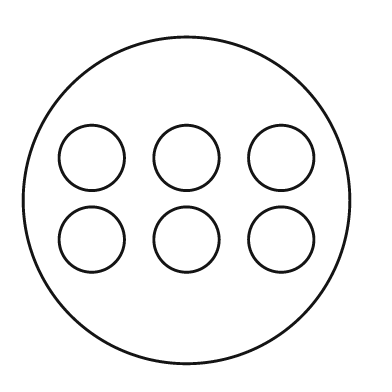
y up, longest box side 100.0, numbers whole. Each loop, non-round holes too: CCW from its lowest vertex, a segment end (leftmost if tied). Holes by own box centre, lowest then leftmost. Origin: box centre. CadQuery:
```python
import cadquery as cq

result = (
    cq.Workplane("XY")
    .moveTo(0.0, 0.0)
    .circle(50.0)
    .moveTo(-29.0, -12.0)
    .circle(10.0)
    .moveTo(0.0, -12.0)
    .circle(10.0)
    .moveTo(29.0, -12.0)
    .circle(10.0)
    .moveTo(-29.0, 13.0)
    .circle(10.0)
    .moveTo(0.0, 13.0)
    .circle(10.0)
    .moveTo(29.0, 13.0)
    .circle(10.0)
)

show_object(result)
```